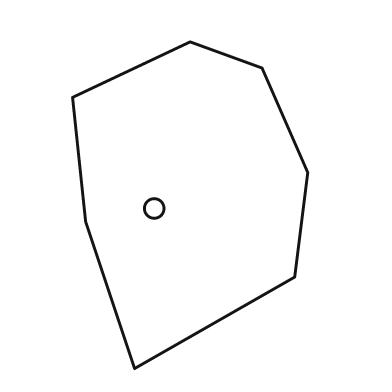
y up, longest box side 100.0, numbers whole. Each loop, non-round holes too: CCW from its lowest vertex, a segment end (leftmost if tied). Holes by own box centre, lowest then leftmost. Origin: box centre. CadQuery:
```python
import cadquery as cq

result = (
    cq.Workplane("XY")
    .moveTo(-17.0, -50.0)
    .lineTo(32.0, -22.0)
    .lineTo(36.0, 10.0)
    .lineTo(22.0, 42.0)
    .lineTo(0.0, 50.0)
    .lineTo(-36.0, 33.0)
    .lineTo(-32.0, -5.0)
    .close()
    .moveTo(-11.0, -1.0)
    .circle(3.0)
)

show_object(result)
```